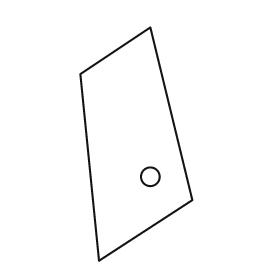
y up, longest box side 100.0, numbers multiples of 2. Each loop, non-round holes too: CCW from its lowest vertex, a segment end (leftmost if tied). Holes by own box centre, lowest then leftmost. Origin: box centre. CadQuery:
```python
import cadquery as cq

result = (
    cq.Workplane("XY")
    .moveTo(-16.0, -50.0)
    .lineTo(24.0, -24.0)
    .lineTo(6.0, 50.0)
    .lineTo(-24.0, 30.0)
    .close()
    .moveTo(6.0, -14.0)
    .circle(4.0)
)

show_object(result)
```